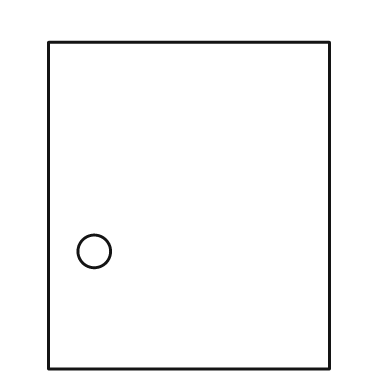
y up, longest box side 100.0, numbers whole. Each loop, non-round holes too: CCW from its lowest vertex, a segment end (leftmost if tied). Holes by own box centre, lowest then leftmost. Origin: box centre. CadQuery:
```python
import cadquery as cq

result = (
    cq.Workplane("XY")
    .moveTo(-43.0, -50.0)
    .lineTo(43.0, -50.0)
    .lineTo(43.0, 50.0)
    .lineTo(-43.0, 50.0)
    .close()
    .moveTo(-29.0, -14.0)
    .circle(5.0)
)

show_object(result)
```